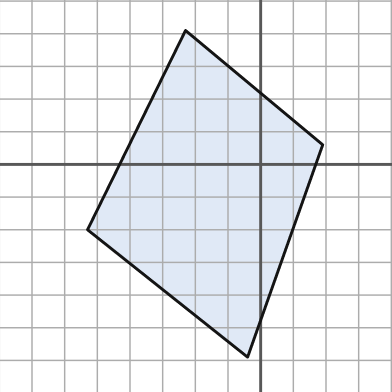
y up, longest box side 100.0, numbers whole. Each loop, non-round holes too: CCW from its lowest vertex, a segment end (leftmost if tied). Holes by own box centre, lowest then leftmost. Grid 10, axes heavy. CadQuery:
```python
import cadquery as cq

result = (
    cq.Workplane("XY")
    .moveTo(-4.0, -59.0)
    .lineTo(19.0, 6.0)
    .lineTo(-23.0, 41.0)
    .lineTo(-53.0, -20.0)
    .close()
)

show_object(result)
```